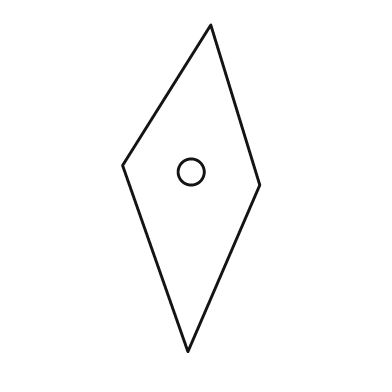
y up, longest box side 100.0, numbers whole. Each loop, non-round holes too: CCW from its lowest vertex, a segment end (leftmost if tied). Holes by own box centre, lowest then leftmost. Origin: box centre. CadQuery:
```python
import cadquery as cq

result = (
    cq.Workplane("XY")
    .moveTo(-1.0, -50.0)
    .lineTo(21.0, 1.0)
    .lineTo(6.0, 50.0)
    .lineTo(-21.0, 7.0)
    .close()
    .moveTo(0.0, 5.0)
    .circle(4.0)
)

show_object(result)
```